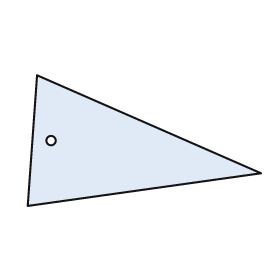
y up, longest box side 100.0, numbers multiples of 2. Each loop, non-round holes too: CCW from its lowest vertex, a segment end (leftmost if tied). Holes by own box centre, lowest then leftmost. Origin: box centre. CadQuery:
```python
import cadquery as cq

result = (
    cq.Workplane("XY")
    .moveTo(-50.0, -28.0)
    .lineTo(50.0, -14.0)
    .lineTo(-46.0, 28.0)
    .close()
    .moveTo(-40.0, 0.0)
    .circle(2.0)
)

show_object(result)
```